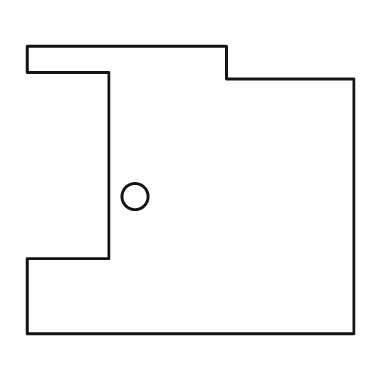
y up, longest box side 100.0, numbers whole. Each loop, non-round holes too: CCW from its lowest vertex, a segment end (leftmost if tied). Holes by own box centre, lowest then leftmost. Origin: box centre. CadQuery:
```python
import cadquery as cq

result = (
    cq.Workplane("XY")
    .moveTo(-50.0, -44.0)
    .lineTo(50.0, -44.0)
    .lineTo(50.0, 34.0)
    .lineTo(11.0, 34.0)
    .lineTo(11.0, 44.0)
    .lineTo(-50.0, 44.0)
    .lineTo(-50.0, 36.0)
    .lineTo(-25.0, 36.0)
    .lineTo(-25.0, -21.0)
    .lineTo(-50.0, -21.0)
    .close()
    .moveTo(-17.0, -2.0)
    .circle(4.0)
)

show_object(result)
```